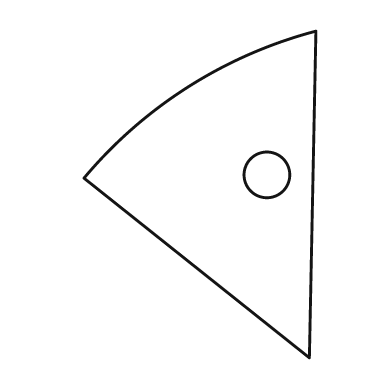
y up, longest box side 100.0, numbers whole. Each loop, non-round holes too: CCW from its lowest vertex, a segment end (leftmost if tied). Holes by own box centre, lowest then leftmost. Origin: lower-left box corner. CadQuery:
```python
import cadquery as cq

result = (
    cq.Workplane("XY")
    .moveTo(69.0, 0.0)
    .lineTo(71.0, 100.0)
    .threePointArc((32.0, 83.0), (0.0, 55.0))
    .close()
    .moveTo(56.0, 56.0)
    .circle(7.0)
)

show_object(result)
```